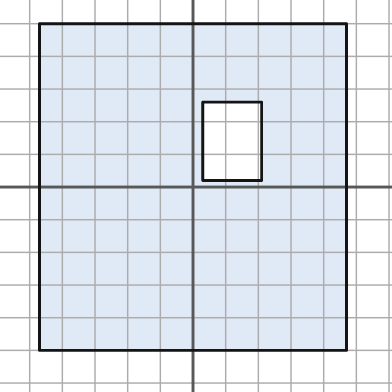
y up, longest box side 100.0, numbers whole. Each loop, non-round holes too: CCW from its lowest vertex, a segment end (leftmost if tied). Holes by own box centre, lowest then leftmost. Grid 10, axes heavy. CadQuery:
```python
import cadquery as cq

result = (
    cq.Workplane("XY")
    .moveTo(-47.0, -50.0)
    .lineTo(47.0, -50.0)
    .lineTo(47.0, 50.0)
    .lineTo(-47.0, 50.0)
    .close()
    .moveTo(3.0, 2.0)
    .lineTo(21.0, 2.0)
    .lineTo(21.0, 26.0)
    .lineTo(3.0, 26.0)
    .close()
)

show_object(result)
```